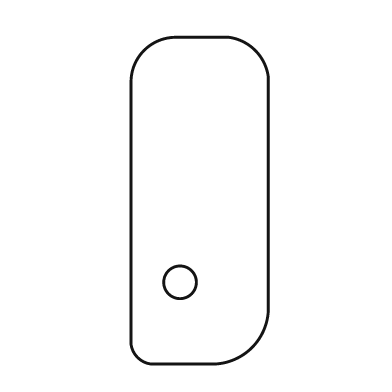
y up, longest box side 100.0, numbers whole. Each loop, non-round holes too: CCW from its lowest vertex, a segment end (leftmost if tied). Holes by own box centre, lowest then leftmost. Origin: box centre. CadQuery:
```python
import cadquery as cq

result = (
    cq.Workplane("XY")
    .moveTo(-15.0, -50.0)
    .lineTo(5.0, -50.0)
    .threePointArc((16.0, -45.0), (21.0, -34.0))
    .lineTo(21.0, 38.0)
    .threePointArc((17.0, 46.0), (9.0, 50.0))
    .lineTo(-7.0, 50.0)
    .threePointArc((-17.0, 46.0), (-21.0, 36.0))
    .lineTo(-21.0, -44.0)
    .threePointArc((-19.0, -48.0), (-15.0, -50.0))
    .close()
    .moveTo(-6.0, -25.0)
    .circle(5.0)
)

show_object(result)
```